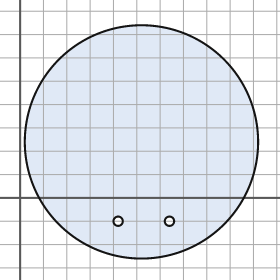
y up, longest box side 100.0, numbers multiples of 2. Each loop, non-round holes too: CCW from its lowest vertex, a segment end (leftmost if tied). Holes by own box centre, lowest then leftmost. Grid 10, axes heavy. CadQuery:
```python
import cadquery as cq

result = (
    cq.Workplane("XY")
    .moveTo(52.0, 24.0)
    .circle(50.0)
    .moveTo(42.0, -10.0)
    .circle(2.0)
    .moveTo(64.0, -10.0)
    .circle(2.0)
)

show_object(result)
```